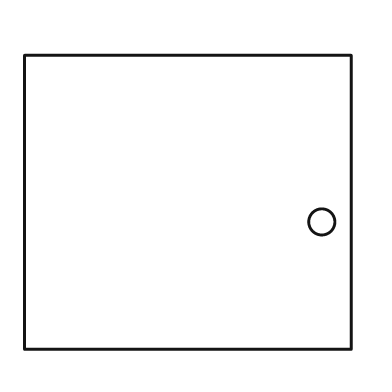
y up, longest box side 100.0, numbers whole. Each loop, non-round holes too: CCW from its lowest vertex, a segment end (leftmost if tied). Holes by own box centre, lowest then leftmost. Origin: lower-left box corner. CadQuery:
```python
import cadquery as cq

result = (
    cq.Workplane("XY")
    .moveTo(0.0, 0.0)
    .lineTo(100.0, 0.0)
    .lineTo(100.0, 90.0)
    .lineTo(0.0, 90.0)
    .close()
    .moveTo(91.0, 39.0)
    .circle(4.0)
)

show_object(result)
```